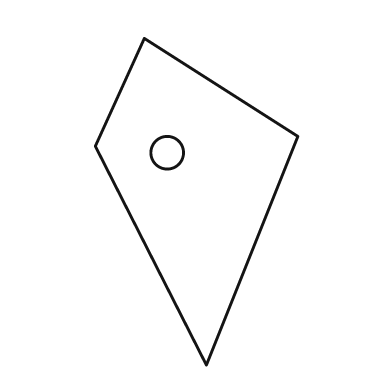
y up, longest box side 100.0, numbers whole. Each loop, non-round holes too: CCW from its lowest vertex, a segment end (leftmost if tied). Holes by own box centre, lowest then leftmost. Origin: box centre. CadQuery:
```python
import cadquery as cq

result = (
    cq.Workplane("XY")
    .moveTo(3.0, -50.0)
    .lineTo(31.0, 20.0)
    .lineTo(-16.0, 50.0)
    .lineTo(-31.0, 17.0)
    .close()
    .moveTo(-9.0, 15.0)
    .circle(5.0)
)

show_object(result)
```